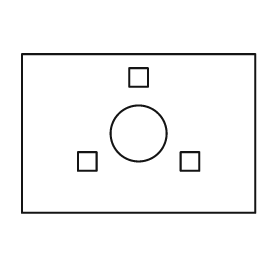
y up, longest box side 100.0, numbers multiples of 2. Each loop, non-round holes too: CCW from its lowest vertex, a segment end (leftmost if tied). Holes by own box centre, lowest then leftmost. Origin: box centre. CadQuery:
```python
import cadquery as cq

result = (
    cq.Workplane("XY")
    .moveTo(-50.0, -34.0)
    .lineTo(50.0, -34.0)
    .lineTo(50.0, 34.0)
    .lineTo(-50.0, 34.0)
    .close()
    .moveTo(-26.0, -16.0)
    .lineTo(-18.0, -16.0)
    .lineTo(-18.0, -8.0)
    .lineTo(-26.0, -8.0)
    .close()
    .moveTo(18.0, -16.0)
    .lineTo(26.0, -16.0)
    .lineTo(26.0, -8.0)
    .lineTo(18.0, -8.0)
    .close()
    .moveTo(0.0, 0.0)
    .circle(12.0)
    .moveTo(-4.0, 20.0)
    .lineTo(4.0, 20.0)
    .lineTo(4.0, 28.0)
    .lineTo(-4.0, 28.0)
    .close()
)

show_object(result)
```